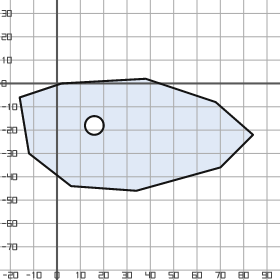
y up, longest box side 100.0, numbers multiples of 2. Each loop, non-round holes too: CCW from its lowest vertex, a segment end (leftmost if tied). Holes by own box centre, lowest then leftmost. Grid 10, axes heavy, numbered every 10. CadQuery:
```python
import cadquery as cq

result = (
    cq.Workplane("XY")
    .moveTo(34.0, -46.0)
    .lineTo(70.0, -36.0)
    .lineTo(84.0, -22.0)
    .lineTo(68.0, -8.0)
    .lineTo(38.0, 2.0)
    .lineTo(2.0, 0.0)
    .lineTo(-16.0, -6.0)
    .lineTo(-12.0, -30.0)
    .lineTo(6.0, -44.0)
    .close()
    .moveTo(16.0, -18.0)
    .circle(4.0)
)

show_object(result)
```